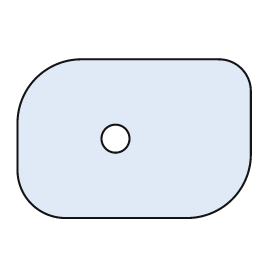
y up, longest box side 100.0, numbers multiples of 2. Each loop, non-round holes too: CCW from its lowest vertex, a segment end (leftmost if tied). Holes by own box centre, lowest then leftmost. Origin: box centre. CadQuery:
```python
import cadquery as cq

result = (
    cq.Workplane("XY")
    .moveTo(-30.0, -34.0)
    .lineTo(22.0, -34.0)
    .threePointArc((42.0, -26.0), (50.0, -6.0))
    .lineTo(50.0, 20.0)
    .threePointArc((46.0, 30.0), (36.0, 34.0))
    .lineTo(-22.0, 34.0)
    .threePointArc((-42.0, 26.0), (-50.0, 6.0))
    .lineTo(-50.0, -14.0)
    .threePointArc((-44.0, -28.0), (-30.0, -34.0))
    .close()
    .moveTo(-8.0, 0.0)
    .circle(6.0)
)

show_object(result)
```